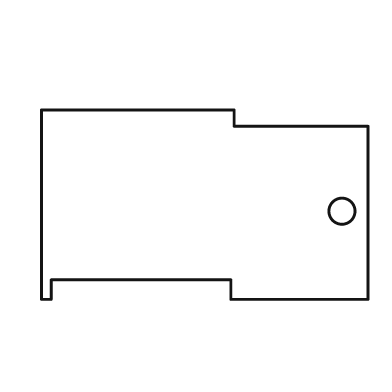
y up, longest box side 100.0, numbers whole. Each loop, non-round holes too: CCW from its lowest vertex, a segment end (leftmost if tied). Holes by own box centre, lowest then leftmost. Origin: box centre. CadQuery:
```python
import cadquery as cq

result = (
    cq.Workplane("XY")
    .moveTo(-50.0, -29.0)
    .lineTo(-47.0, -29.0)
    .lineTo(-47.0, -23.0)
    .lineTo(8.0, -23.0)
    .lineTo(8.0, -29.0)
    .lineTo(50.0, -29.0)
    .lineTo(50.0, 24.0)
    .lineTo(9.0, 24.0)
    .lineTo(9.0, 29.0)
    .lineTo(-50.0, 29.0)
    .close()
    .moveTo(42.0, -2.0)
    .circle(4.0)
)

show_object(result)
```